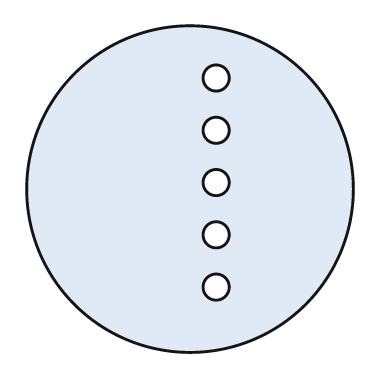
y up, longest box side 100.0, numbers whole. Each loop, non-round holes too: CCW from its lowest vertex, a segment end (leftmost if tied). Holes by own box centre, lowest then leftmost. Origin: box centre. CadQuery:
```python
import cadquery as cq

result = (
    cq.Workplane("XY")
    .moveTo(0.0, 0.0)
    .circle(50.0)
    .moveTo(8.0, -30.0)
    .circle(4.0)
    .moveTo(8.0, -14.0)
    .circle(4.0)
    .moveTo(8.0, 2.0)
    .circle(4.0)
    .moveTo(8.0, 18.0)
    .circle(4.0)
    .moveTo(8.0, 34.0)
    .circle(4.0)
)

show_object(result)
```